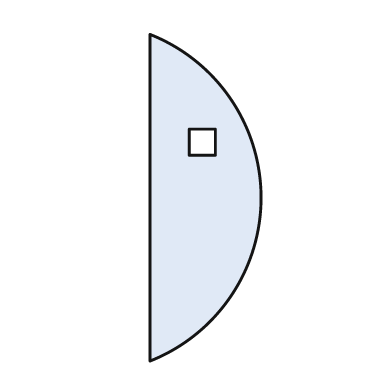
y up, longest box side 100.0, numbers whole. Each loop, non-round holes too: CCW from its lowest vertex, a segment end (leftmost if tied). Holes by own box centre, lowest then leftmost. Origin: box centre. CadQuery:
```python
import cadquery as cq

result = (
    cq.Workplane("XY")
    .moveTo(-17.0, -50.0)
    .threePointArc((17.0, 0.0), (-17.0, 50.0))
    .close()
    .moveTo(-5.0, 13.0)
    .lineTo(3.0, 13.0)
    .lineTo(3.0, 21.0)
    .lineTo(-5.0, 21.0)
    .close()
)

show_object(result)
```